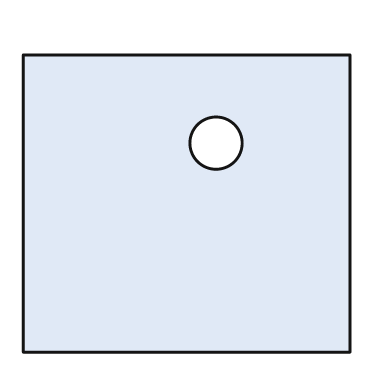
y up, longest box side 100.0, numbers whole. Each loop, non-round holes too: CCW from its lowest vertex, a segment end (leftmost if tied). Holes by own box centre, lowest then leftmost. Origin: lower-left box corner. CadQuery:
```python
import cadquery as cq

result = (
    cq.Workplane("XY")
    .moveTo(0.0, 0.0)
    .lineTo(100.0, 0.0)
    .lineTo(100.0, 91.0)
    .lineTo(0.0, 91.0)
    .close()
    .moveTo(59.0, 64.0)
    .circle(8.0)
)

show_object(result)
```